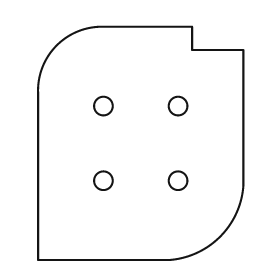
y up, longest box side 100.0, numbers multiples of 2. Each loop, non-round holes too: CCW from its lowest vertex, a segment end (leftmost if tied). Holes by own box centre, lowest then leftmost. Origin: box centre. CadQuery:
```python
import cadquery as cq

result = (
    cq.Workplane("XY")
    .moveTo(-44.0, -50.0)
    .lineTo(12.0, -50.0)
    .threePointArc((34.0, -40.0), (44.0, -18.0))
    .lineTo(44.0, 40.0)
    .lineTo(22.0, 40.0)
    .lineTo(22.0, 50.0)
    .lineTo(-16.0, 50.0)
    .threePointArc((-36.0, 42.0), (-44.0, 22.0))
    .close()
    .moveTo(-16.0, -16.0)
    .circle(4.0)
    .moveTo(16.0, -16.0)
    .circle(4.0)
    .moveTo(-16.0, 16.0)
    .circle(4.0)
    .moveTo(16.0, 16.0)
    .circle(4.0)
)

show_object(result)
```